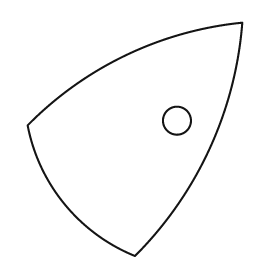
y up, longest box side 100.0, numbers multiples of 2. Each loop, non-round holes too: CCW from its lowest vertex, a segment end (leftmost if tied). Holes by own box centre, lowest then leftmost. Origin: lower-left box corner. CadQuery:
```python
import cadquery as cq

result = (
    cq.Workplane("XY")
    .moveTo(46.0, 0.0)
    .threePointArc((78.0, 46.0), (92.0, 100.0))
    .threePointArc((42.0, 86.0), (0.0, 56.0))
    .threePointArc((16.0, 22.0), (46.0, 0.0))
    .close()
    .moveTo(64.0, 58.0)
    .circle(6.0)
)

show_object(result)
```